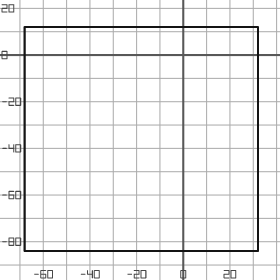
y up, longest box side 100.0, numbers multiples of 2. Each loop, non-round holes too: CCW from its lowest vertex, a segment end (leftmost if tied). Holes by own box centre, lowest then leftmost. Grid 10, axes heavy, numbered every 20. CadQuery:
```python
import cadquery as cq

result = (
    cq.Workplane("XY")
    .moveTo(-68.0, -84.0)
    .lineTo(32.0, -84.0)
    .lineTo(32.0, 12.0)
    .lineTo(-68.0, 12.0)
    .close()
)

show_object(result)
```